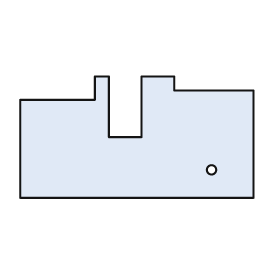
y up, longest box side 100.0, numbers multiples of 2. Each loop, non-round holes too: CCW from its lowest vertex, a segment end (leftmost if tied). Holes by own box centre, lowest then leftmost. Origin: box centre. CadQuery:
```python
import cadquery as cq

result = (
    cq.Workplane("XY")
    .moveTo(-50.0, -26.0)
    .lineTo(50.0, -26.0)
    .lineTo(50.0, 20.0)
    .lineTo(16.0, 20.0)
    .lineTo(16.0, 26.0)
    .lineTo(2.0, 26.0)
    .lineTo(2.0, 0.0)
    .lineTo(-12.0, 0.0)
    .lineTo(-12.0, 26.0)
    .lineTo(-18.0, 26.0)
    .lineTo(-18.0, 16.0)
    .lineTo(-50.0, 16.0)
    .close()
    .moveTo(32.0, -14.0)
    .circle(2.0)
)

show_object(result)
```